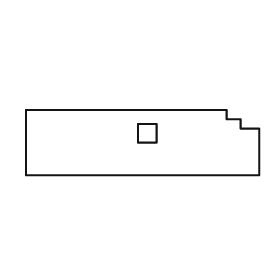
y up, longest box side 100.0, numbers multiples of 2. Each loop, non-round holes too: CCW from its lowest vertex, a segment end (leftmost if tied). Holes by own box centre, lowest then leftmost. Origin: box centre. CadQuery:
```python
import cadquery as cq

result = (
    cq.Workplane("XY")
    .moveTo(-50.0, -14.0)
    .lineTo(50.0, -14.0)
    .lineTo(50.0, 6.0)
    .lineTo(42.0, 6.0)
    .lineTo(42.0, 10.0)
    .lineTo(36.0, 10.0)
    .lineTo(36.0, 14.0)
    .lineTo(-50.0, 14.0)
    .close()
    .moveTo(-2.0, 0.0)
    .lineTo(6.0, 0.0)
    .lineTo(6.0, 8.0)
    .lineTo(-2.0, 8.0)
    .close()
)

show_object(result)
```